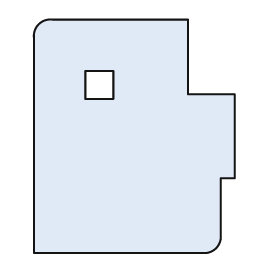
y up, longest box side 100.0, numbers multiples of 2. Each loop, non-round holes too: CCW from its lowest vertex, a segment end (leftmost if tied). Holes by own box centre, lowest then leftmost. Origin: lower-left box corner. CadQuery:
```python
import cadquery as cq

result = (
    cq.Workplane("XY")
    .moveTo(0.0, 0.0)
    .lineTo(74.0, 0.0)
    .threePointArc((78.0, 2.0), (80.0, 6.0))
    .lineTo(80.0, 32.0)
    .lineTo(86.0, 32.0)
    .lineTo(86.0, 68.0)
    .lineTo(66.0, 68.0)
    .lineTo(66.0, 100.0)
    .lineTo(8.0, 100.0)
    .threePointArc((2.0, 98.0), (0.0, 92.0))
    .close()
    .moveTo(22.0, 66.0)
    .lineTo(34.0, 66.0)
    .lineTo(34.0, 78.0)
    .lineTo(22.0, 78.0)
    .close()
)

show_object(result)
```